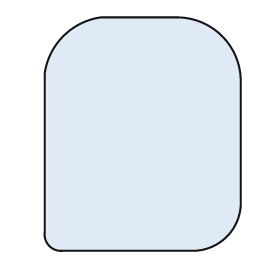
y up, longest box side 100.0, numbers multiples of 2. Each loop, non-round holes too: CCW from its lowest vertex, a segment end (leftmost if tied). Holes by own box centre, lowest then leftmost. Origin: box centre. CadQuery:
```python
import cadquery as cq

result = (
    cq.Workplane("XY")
    .moveTo(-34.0, -50.0)
    .lineTo(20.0, -50.0)
    .threePointArc((36.0, -44.0), (42.0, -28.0))
    .lineTo(42.0, 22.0)
    .threePointArc((34.0, 42.0), (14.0, 50.0))
    .lineTo(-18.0, 50.0)
    .threePointArc((-34.0, 42.0), (-42.0, 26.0))
    .lineTo(-42.0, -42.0)
    .threePointArc((-40.0, -48.0), (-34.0, -50.0))
    .close()
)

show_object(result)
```